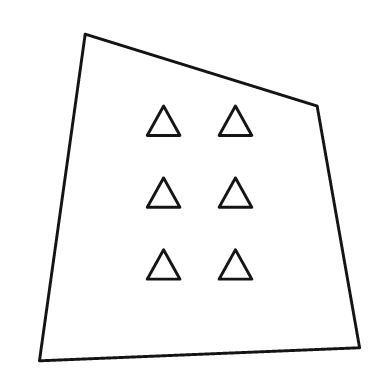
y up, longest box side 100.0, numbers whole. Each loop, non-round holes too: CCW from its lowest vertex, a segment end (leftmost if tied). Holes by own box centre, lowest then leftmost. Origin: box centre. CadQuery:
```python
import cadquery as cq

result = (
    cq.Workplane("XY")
    .moveTo(-49.0, -50.0)
    .lineTo(49.0, -46.0)
    .lineTo(36.0, 28.0)
    .lineTo(-35.0, 50.0)
    .close()
    .moveTo(-16.0, -25.0)
    .lineTo(-6.0, -25.0)
    .lineTo(-11.0, -16.0)
    .close()
    .moveTo(6.0, -25.0)
    .lineTo(16.0, -25.0)
    .lineTo(11.0, -16.0)
    .close()
    .moveTo(-16.0, -3.0)
    .lineTo(-6.0, -3.0)
    .lineTo(-11.0, 6.0)
    .close()
    .moveTo(6.0, -3.0)
    .lineTo(16.0, -3.0)
    .lineTo(11.0, 6.0)
    .close()
    .moveTo(-16.0, 19.0)
    .lineTo(-6.0, 19.0)
    .lineTo(-11.0, 28.0)
    .close()
    .moveTo(6.0, 19.0)
    .lineTo(16.0, 19.0)
    .lineTo(11.0, 28.0)
    .close()
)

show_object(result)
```